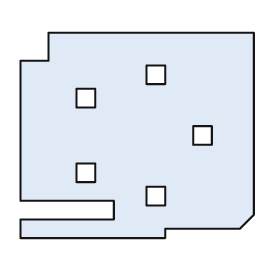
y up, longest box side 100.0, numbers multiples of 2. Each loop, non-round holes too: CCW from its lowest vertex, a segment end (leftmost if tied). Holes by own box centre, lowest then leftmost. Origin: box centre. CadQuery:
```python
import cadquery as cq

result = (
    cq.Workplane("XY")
    .moveTo(-50.0, -44.0)
    .lineTo(12.0, -44.0)
    .lineTo(12.0, -40.0)
    .lineTo(44.0, -40.0)
    .lineTo(50.0, -34.0)
    .lineTo(50.0, 44.0)
    .lineTo(-38.0, 44.0)
    .lineTo(-38.0, 32.0)
    .lineTo(-50.0, 32.0)
    .lineTo(-50.0, -28.0)
    .lineTo(-10.0, -28.0)
    .lineTo(-10.0, -36.0)
    .lineTo(-50.0, -36.0)
    .close()
    .moveTo(4.0, -30.0)
    .lineTo(12.0, -30.0)
    .lineTo(12.0, -22.0)
    .lineTo(4.0, -22.0)
    .close()
    .moveTo(-26.0, -20.0)
    .lineTo(-18.0, -20.0)
    .lineTo(-18.0, -12.0)
    .lineTo(-26.0, -12.0)
    .close()
    .moveTo(24.0, -4.0)
    .lineTo(32.0, -4.0)
    .lineTo(32.0, 4.0)
    .lineTo(24.0, 4.0)
    .close()
    .moveTo(-26.0, 12.0)
    .lineTo(-18.0, 12.0)
    .lineTo(-18.0, 20.0)
    .lineTo(-26.0, 20.0)
    .close()
    .moveTo(4.0, 22.0)
    .lineTo(12.0, 22.0)
    .lineTo(12.0, 30.0)
    .lineTo(4.0, 30.0)
    .close()
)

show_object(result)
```